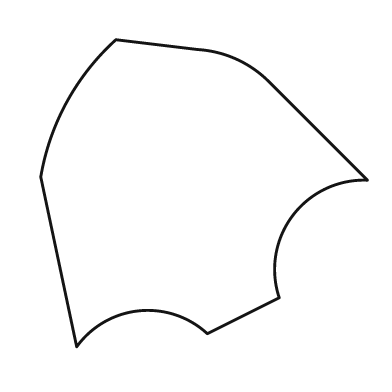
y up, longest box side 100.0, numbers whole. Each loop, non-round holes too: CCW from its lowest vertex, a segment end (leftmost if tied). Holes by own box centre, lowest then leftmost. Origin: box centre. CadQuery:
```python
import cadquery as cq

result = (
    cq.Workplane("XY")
    .moveTo(-39.0, -47.0)
    .threePointArc((-20.0, -36.0), (1.0, -43.0))
    .lineTo(23.0, -32.0)
    .threePointArc((27.0, -7.0), (50.0, 4.0))
    .lineTo(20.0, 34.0)
    .threePointArc((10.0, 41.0), (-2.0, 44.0))
    .lineTo(-27.0, 47.0)
    .threePointArc((-42.0, 28.0), (-50.0, 5.0))
    .close()
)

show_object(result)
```